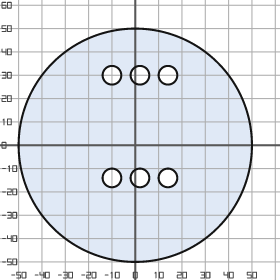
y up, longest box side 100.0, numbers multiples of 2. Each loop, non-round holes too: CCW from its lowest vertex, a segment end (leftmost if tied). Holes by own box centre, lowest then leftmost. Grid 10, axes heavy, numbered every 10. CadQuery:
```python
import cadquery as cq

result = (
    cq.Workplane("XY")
    .moveTo(0.0, 0.0)
    .circle(50.0)
    .moveTo(-10.0, -14.0)
    .circle(4.0)
    .moveTo(2.0, -14.0)
    .circle(4.0)
    .moveTo(14.0, -14.0)
    .circle(4.0)
    .moveTo(-10.0, 30.0)
    .circle(4.0)
    .moveTo(2.0, 30.0)
    .circle(4.0)
    .moveTo(14.0, 30.0)
    .circle(4.0)
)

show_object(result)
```